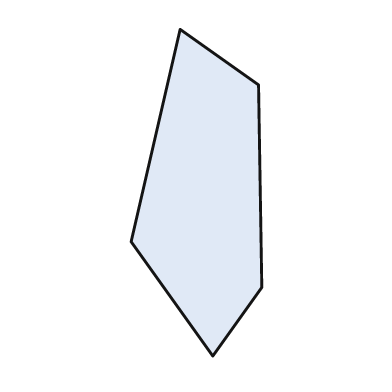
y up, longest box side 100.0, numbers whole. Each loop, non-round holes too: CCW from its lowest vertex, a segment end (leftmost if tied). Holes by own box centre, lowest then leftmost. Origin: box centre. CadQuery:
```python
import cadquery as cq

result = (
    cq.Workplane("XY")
    .moveTo(5.0, -50.0)
    .lineTo(20.0, -29.0)
    .lineTo(19.0, 33.0)
    .lineTo(-5.0, 50.0)
    .lineTo(-20.0, -15.0)
    .close()
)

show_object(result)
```